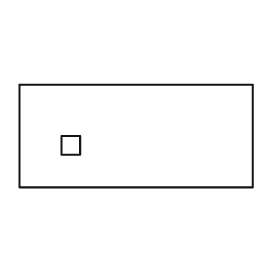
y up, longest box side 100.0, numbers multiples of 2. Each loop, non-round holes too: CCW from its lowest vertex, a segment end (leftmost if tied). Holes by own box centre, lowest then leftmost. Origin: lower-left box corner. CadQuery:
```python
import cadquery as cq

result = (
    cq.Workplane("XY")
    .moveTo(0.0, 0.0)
    .lineTo(100.0, 0.0)
    .lineTo(100.0, 44.0)
    .lineTo(0.0, 44.0)
    .close()
    .moveTo(18.0, 14.0)
    .lineTo(26.0, 14.0)
    .lineTo(26.0, 22.0)
    .lineTo(18.0, 22.0)
    .close()
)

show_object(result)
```